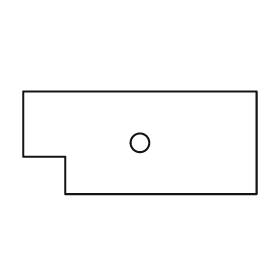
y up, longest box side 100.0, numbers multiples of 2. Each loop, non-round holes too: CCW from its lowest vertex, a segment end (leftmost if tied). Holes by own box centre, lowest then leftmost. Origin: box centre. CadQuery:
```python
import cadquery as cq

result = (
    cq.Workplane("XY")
    .moveTo(-32.0, -22.0)
    .lineTo(50.0, -22.0)
    .lineTo(50.0, 22.0)
    .lineTo(-50.0, 22.0)
    .lineTo(-50.0, -6.0)
    .lineTo(-32.0, -6.0)
    .close()
    .moveTo(0.0, 0.0)
    .circle(4.0)
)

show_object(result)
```